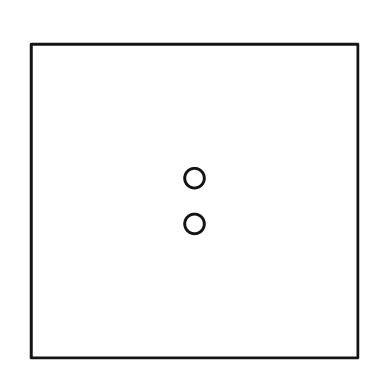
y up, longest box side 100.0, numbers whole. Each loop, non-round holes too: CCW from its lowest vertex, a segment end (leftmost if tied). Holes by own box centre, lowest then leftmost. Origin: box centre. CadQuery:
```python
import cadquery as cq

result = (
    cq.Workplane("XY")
    .moveTo(-50.0, -48.0)
    .lineTo(50.0, -48.0)
    .lineTo(50.0, 48.0)
    .lineTo(-50.0, 48.0)
    .close()
    .moveTo(0.0, -7.0)
    .circle(3.0)
    .moveTo(0.0, 7.0)
    .circle(3.0)
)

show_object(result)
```